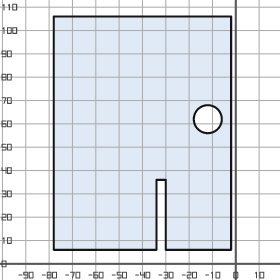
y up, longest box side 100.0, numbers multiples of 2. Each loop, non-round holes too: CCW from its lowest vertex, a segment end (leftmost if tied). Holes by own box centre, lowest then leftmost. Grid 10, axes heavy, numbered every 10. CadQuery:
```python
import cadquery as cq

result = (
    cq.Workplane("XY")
    .moveTo(-78.0, 6.0)
    .lineTo(-34.0, 6.0)
    .lineTo(-34.0, 36.0)
    .lineTo(-30.0, 36.0)
    .lineTo(-30.0, 6.0)
    .lineTo(-2.0, 6.0)
    .lineTo(-2.0, 106.0)
    .lineTo(-78.0, 106.0)
    .close()
    .moveTo(-12.0, 62.0)
    .circle(6.0)
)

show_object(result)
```